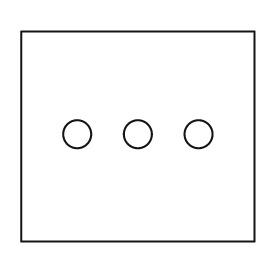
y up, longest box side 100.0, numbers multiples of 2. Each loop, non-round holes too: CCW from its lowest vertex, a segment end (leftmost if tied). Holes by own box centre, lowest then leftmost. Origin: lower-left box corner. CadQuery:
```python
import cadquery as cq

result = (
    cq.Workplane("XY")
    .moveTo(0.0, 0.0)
    .lineTo(100.0, 0.0)
    .lineTo(100.0, 90.0)
    .lineTo(0.0, 90.0)
    .close()
    .moveTo(24.0, 46.0)
    .circle(6.0)
    .moveTo(50.0, 46.0)
    .circle(6.0)
    .moveTo(76.0, 46.0)
    .circle(6.0)
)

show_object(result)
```